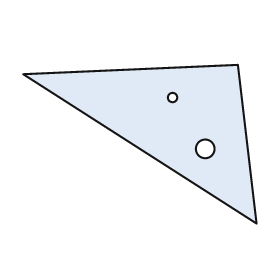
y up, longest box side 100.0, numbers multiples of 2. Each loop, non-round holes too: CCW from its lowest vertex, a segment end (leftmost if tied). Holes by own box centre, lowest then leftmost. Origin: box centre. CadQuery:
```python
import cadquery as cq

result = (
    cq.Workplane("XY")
    .moveTo(50.0, -34.0)
    .lineTo(42.0, 34.0)
    .lineTo(-50.0, 30.0)
    .close()
    .moveTo(28.0, -2.0)
    .circle(4.0)
    .moveTo(14.0, 20.0)
    .circle(2.0)
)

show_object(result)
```